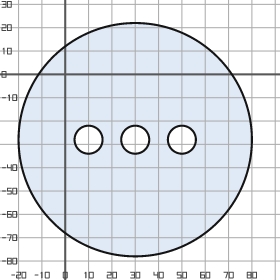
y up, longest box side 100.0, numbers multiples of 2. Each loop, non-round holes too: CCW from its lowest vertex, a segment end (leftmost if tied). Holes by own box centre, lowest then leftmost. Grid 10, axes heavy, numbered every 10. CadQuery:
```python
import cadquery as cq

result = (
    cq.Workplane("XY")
    .moveTo(30.0, -28.0)
    .circle(50.0)
    .moveTo(10.0, -28.0)
    .circle(6.0)
    .moveTo(30.0, -28.0)
    .circle(6.0)
    .moveTo(50.0, -28.0)
    .circle(6.0)
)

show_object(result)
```